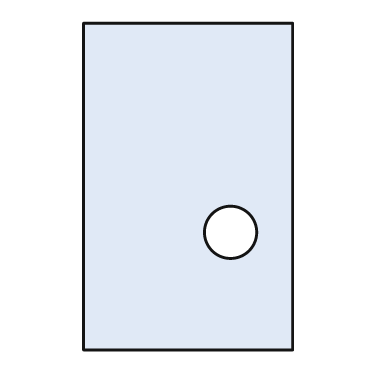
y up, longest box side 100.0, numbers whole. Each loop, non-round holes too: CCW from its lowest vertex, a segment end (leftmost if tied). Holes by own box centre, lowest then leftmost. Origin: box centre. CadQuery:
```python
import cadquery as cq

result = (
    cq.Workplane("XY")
    .moveTo(-32.0, -50.0)
    .lineTo(32.0, -50.0)
    .lineTo(32.0, 50.0)
    .lineTo(-32.0, 50.0)
    .close()
    .moveTo(13.0, -14.0)
    .circle(8.0)
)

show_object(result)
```